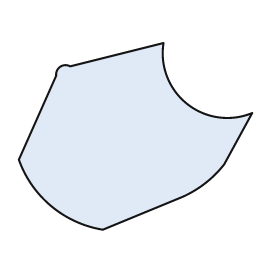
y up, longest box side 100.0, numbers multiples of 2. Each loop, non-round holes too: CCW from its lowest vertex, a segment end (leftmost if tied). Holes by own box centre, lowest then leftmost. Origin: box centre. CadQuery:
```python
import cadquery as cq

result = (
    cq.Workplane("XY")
    .moveTo(-14.0, -40.0)
    .lineTo(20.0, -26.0)
    .threePointArc((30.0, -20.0), (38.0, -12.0))
    .lineTo(50.0, 10.0)
    .threePointArc((22.0, 14.0), (12.0, 40.0))
    .lineTo(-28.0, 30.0)
    .threePointArc((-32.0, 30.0), (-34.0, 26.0))
    .lineTo(-50.0, -10.0)
    .threePointArc((-36.0, -30.0), (-14.0, -40.0))
    .close()
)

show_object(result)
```